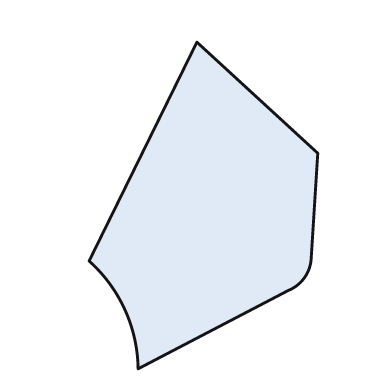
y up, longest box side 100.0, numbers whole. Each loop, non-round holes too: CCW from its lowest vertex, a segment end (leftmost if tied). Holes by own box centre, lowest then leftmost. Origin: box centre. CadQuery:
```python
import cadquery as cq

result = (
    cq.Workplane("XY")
    .moveTo(-20.0, -50.0)
    .lineTo(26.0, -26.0)
    .threePointArc((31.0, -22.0), (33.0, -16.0))
    .lineTo(35.0, 16.0)
    .lineTo(-2.0, 50.0)
    .lineTo(-35.0, -17.0)
    .threePointArc((-24.0, -32.0), (-20.0, -50.0))
    .close()
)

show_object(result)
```